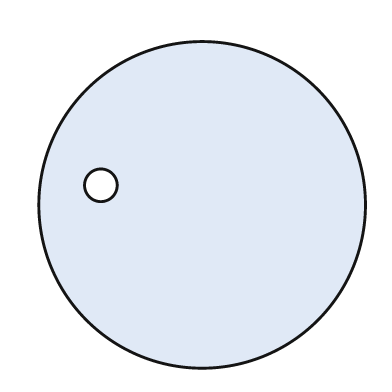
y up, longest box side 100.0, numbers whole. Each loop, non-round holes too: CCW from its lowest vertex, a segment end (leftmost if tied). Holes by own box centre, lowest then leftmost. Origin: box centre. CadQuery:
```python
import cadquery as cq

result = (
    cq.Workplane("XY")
    .moveTo(0.0, 0.0)
    .circle(50.0)
    .moveTo(-31.0, 6.0)
    .circle(5.0)
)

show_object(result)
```